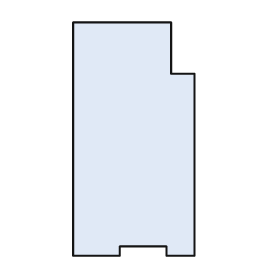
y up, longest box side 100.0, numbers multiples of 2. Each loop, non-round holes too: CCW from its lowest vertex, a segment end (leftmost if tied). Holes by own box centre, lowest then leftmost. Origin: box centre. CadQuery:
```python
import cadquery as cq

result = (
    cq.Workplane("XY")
    .moveTo(-26.0, -50.0)
    .lineTo(-6.0, -50.0)
    .lineTo(-6.0, -46.0)
    .lineTo(14.0, -46.0)
    .lineTo(14.0, -50.0)
    .lineTo(26.0, -50.0)
    .lineTo(26.0, 28.0)
    .lineTo(16.0, 28.0)
    .lineTo(16.0, 50.0)
    .lineTo(-26.0, 50.0)
    .close()
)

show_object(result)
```